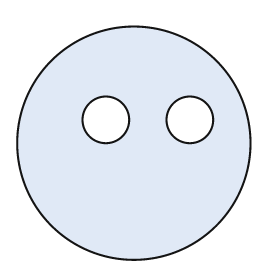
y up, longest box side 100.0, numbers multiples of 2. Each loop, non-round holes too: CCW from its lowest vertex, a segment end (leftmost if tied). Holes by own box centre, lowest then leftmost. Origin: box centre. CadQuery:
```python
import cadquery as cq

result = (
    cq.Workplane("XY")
    .moveTo(0.0, 0.0)
    .circle(50.0)
    .moveTo(-12.0, 10.0)
    .circle(10.0)
    .moveTo(24.0, 10.0)
    .circle(10.0)
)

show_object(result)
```